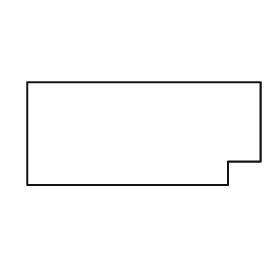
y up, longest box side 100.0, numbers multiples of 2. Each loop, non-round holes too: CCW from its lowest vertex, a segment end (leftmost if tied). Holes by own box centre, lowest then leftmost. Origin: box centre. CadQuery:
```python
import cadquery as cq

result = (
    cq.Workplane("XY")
    .moveTo(-50.0, -22.0)
    .lineTo(36.0, -22.0)
    .lineTo(36.0, -12.0)
    .lineTo(50.0, -12.0)
    .lineTo(50.0, 22.0)
    .lineTo(-50.0, 22.0)
    .close()
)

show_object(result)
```